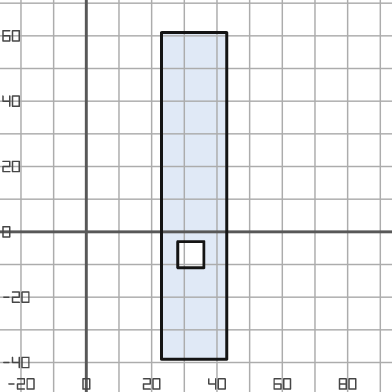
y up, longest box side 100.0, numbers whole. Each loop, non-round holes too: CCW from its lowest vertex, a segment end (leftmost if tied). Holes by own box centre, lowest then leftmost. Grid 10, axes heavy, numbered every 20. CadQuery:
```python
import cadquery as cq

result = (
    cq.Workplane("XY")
    .moveTo(23.0, -39.0)
    .lineTo(43.0, -39.0)
    .lineTo(43.0, 61.0)
    .lineTo(23.0, 61.0)
    .close()
    .moveTo(28.0, -11.0)
    .lineTo(36.0, -11.0)
    .lineTo(36.0, -3.0)
    .lineTo(28.0, -3.0)
    .close()
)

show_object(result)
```